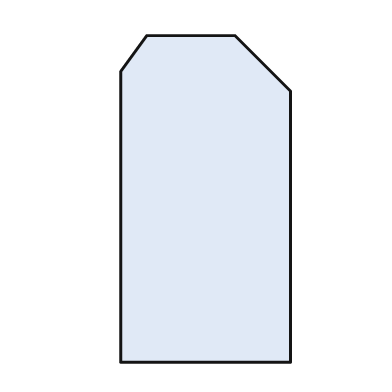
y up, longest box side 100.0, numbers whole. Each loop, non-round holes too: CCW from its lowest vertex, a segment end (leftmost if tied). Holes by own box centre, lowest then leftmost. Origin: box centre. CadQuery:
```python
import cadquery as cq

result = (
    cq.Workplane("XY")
    .moveTo(-26.0, -50.0)
    .lineTo(26.0, -50.0)
    .lineTo(26.0, 33.0)
    .lineTo(9.0, 50.0)
    .lineTo(-18.0, 50.0)
    .lineTo(-26.0, 39.0)
    .close()
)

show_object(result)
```